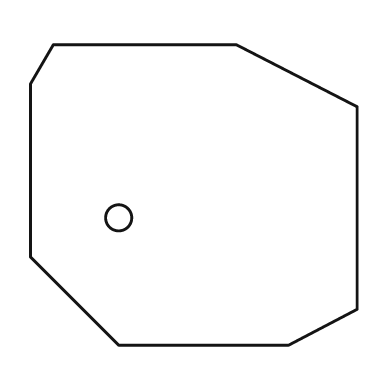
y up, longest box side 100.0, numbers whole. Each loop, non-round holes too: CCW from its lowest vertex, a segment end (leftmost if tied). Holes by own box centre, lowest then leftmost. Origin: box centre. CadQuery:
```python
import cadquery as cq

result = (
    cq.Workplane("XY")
    .moveTo(-23.0, -46.0)
    .lineTo(29.0, -46.0)
    .lineTo(50.0, -35.0)
    .lineTo(50.0, 27.0)
    .lineTo(13.0, 46.0)
    .lineTo(-43.0, 46.0)
    .lineTo(-50.0, 34.0)
    .lineTo(-50.0, -19.0)
    .close()
    .moveTo(-23.0, -7.0)
    .circle(4.0)
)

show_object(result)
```